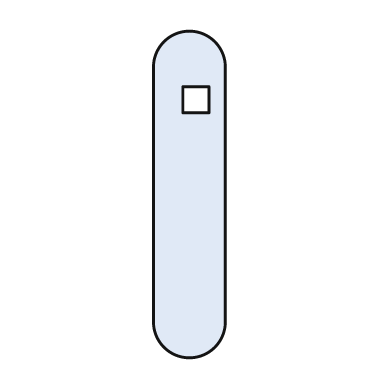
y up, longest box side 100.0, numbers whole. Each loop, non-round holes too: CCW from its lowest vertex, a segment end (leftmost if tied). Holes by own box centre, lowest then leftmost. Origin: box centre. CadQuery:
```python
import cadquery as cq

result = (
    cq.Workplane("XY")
    .moveTo(-11.0, -39.0)
    .threePointArc((0.0, -50.0), (11.0, -39.0))
    .lineTo(11.0, 39.0)
    .threePointArc((0.0, 50.0), (-11.0, 39.0))
    .close()
    .moveTo(-2.0, 25.0)
    .lineTo(6.0, 25.0)
    .lineTo(6.0, 33.0)
    .lineTo(-2.0, 33.0)
    .close()
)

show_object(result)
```